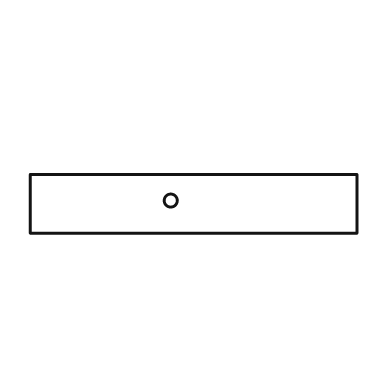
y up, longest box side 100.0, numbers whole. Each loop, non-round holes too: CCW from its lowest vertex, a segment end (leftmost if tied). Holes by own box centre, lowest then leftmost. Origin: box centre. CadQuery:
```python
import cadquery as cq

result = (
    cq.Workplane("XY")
    .moveTo(-50.0, -9.0)
    .lineTo(50.0, -9.0)
    .lineTo(50.0, 9.0)
    .lineTo(-50.0, 9.0)
    .close()
    .moveTo(-7.0, 1.0)
    .circle(2.0)
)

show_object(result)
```